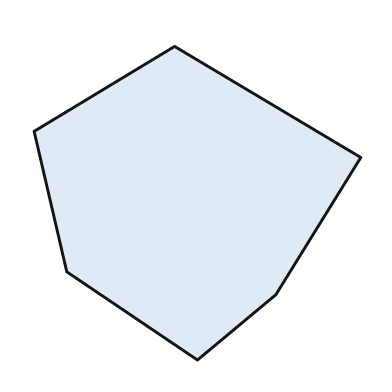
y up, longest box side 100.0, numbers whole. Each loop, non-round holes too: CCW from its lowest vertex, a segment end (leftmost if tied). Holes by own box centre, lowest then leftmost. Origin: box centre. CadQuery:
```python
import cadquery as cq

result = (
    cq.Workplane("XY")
    .moveTo(0.0, -48.0)
    .lineTo(24.0, -28.0)
    .lineTo(50.0, 14.0)
    .lineTo(-7.0, 48.0)
    .lineTo(-50.0, 22.0)
    .lineTo(-40.0, -21.0)
    .close()
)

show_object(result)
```